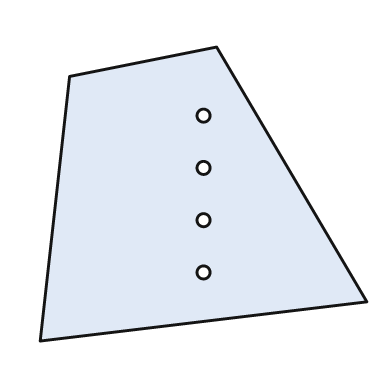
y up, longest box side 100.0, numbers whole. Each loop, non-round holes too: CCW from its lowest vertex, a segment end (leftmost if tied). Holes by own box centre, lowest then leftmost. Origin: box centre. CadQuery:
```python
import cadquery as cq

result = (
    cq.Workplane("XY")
    .moveTo(-50.0, -45.0)
    .lineTo(50.0, -33.0)
    .lineTo(4.0, 45.0)
    .lineTo(-41.0, 36.0)
    .close()
    .moveTo(0.0, -24.0)
    .circle(2.0)
    .moveTo(0.0, -8.0)
    .circle(2.0)
    .moveTo(0.0, 8.0)
    .circle(2.0)
    .moveTo(0.0, 24.0)
    .circle(2.0)
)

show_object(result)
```